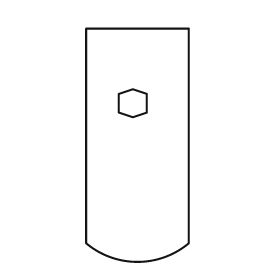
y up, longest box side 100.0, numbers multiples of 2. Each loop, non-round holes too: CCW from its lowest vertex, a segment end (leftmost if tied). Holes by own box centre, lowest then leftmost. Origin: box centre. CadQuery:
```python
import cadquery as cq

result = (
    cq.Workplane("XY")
    .moveTo(-22.0, -42.0)
    .threePointArc((0.0, -50.0), (22.0, -42.0))
    .lineTo(22.0, 50.0)
    .lineTo(-22.0, 50.0)
    .close()
    .moveTo(-2.0, 12.0)
    .lineTo(4.0, 14.0)
    .lineTo(4.0, 22.0)
    .lineTo(-2.0, 24.0)
    .lineTo(-8.0, 22.0)
    .lineTo(-8.0, 14.0)
    .close()
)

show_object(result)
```